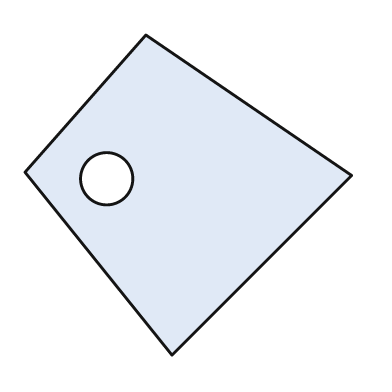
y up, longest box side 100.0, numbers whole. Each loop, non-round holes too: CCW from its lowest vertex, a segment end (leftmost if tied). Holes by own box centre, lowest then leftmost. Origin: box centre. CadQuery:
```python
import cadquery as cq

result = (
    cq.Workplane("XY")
    .moveTo(-5.0, -49.0)
    .lineTo(50.0, 6.0)
    .lineTo(-13.0, 49.0)
    .lineTo(-50.0, 7.0)
    .close()
    .moveTo(-25.0, 5.0)
    .circle(8.0)
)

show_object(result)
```